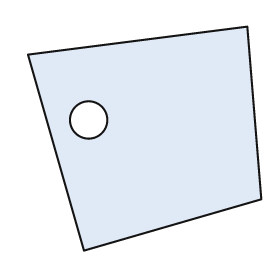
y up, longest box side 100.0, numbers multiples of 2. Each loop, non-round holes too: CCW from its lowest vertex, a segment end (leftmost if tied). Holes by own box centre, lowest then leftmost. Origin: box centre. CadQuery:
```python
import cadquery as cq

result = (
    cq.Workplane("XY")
    .moveTo(-26.0, -48.0)
    .lineTo(50.0, -26.0)
    .lineTo(44.0, 48.0)
    .lineTo(-50.0, 36.0)
    .close()
    .moveTo(-24.0, 8.0)
    .circle(8.0)
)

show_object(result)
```